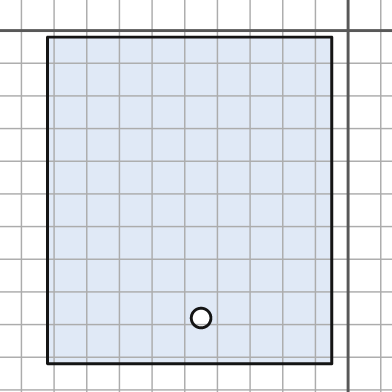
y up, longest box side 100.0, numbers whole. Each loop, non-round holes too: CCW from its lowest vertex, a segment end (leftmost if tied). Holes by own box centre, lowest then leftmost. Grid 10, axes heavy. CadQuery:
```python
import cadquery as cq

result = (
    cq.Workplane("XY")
    .moveTo(-92.0, -102.0)
    .lineTo(-5.0, -102.0)
    .lineTo(-5.0, -2.0)
    .lineTo(-92.0, -2.0)
    .close()
    .moveTo(-45.0, -88.0)
    .circle(3.0)
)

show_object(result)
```